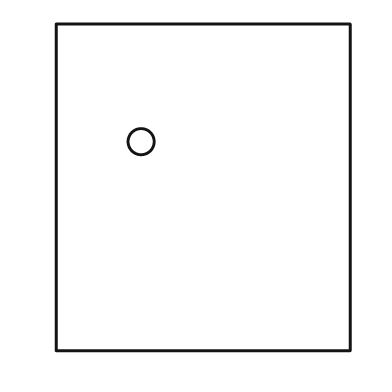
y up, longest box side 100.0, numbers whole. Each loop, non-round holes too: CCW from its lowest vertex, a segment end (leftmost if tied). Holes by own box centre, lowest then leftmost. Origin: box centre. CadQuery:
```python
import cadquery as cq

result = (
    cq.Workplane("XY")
    .moveTo(-45.0, -50.0)
    .lineTo(45.0, -50.0)
    .lineTo(45.0, 50.0)
    .lineTo(-45.0, 50.0)
    .close()
    .moveTo(-19.0, 14.0)
    .circle(4.0)
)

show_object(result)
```